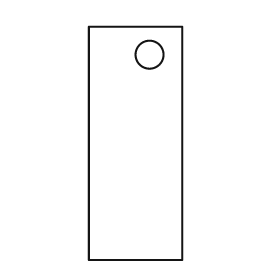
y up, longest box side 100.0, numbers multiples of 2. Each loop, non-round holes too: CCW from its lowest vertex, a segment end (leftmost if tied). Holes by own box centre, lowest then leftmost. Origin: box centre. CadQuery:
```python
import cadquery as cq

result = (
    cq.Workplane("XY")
    .moveTo(-20.0, -50.0)
    .lineTo(20.0, -50.0)
    .lineTo(20.0, 50.0)
    .lineTo(-20.0, 50.0)
    .close()
    .moveTo(6.0, 38.0)
    .circle(6.0)
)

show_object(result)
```